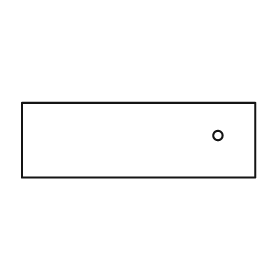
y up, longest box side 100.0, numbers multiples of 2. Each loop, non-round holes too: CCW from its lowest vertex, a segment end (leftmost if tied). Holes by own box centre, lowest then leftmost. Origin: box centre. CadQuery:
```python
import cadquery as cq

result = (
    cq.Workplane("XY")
    .moveTo(-50.0, -16.0)
    .lineTo(50.0, -16.0)
    .lineTo(50.0, 16.0)
    .lineTo(-50.0, 16.0)
    .close()
    .moveTo(34.0, 2.0)
    .circle(2.0)
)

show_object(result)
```